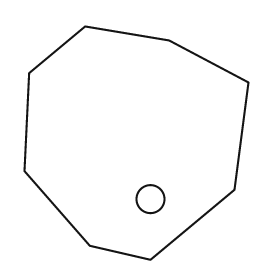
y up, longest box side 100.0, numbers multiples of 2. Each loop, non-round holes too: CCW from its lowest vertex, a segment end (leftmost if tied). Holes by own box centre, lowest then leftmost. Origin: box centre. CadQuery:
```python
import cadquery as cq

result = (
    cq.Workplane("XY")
    .moveTo(6.0, -50.0)
    .lineTo(42.0, -20.0)
    .lineTo(48.0, 26.0)
    .lineTo(14.0, 44.0)
    .lineTo(-22.0, 50.0)
    .lineTo(-46.0, 30.0)
    .lineTo(-48.0, -12.0)
    .lineTo(-20.0, -44.0)
    .close()
    .moveTo(6.0, -24.0)
    .circle(6.0)
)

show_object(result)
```